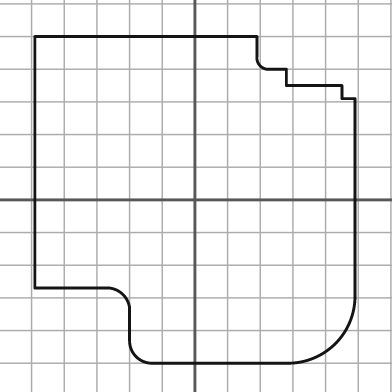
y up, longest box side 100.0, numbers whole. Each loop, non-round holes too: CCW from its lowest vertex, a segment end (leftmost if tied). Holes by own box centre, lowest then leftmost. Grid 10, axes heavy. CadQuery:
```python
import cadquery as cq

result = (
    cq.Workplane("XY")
    .moveTo(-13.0, -50.0)
    .lineTo(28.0, -50.0)
    .threePointArc((43.0, -44.0), (49.0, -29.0))
    .lineTo(49.0, 31.0)
    .lineTo(45.0, 31.0)
    .lineTo(45.0, 35.0)
    .lineTo(28.0, 35.0)
    .lineTo(28.0, 40.0)
    .lineTo(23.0, 40.0)
    .threePointArc((20.0, 41.0), (19.0, 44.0))
    .lineTo(19.0, 50.0)
    .lineTo(-49.0, 50.0)
    .lineTo(-49.0, -27.0)
    .lineTo(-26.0, -27.0)
    .threePointArc((-22.0, -29.0), (-20.0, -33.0))
    .lineTo(-20.0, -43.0)
    .threePointArc((-18.0, -48.0), (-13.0, -50.0))
    .close()
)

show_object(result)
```